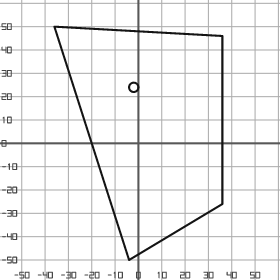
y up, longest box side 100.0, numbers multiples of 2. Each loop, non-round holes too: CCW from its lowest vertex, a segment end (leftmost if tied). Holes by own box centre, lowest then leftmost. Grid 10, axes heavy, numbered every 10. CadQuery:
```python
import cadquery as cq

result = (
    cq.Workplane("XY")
    .moveTo(-4.0, -50.0)
    .lineTo(36.0, -26.0)
    .lineTo(36.0, 46.0)
    .lineTo(-36.0, 50.0)
    .close()
    .moveTo(-2.0, 24.0)
    .circle(2.0)
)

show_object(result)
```